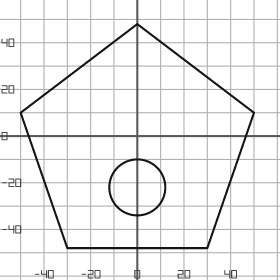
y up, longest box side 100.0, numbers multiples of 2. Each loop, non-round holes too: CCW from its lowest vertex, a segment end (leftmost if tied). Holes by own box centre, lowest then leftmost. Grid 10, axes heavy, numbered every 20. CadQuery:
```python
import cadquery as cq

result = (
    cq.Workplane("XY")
    .moveTo(-30.0, -48.0)
    .lineTo(30.0, -48.0)
    .lineTo(50.0, 10.0)
    .lineTo(0.0, 48.0)
    .lineTo(-50.0, 10.0)
    .close()
    .moveTo(0.0, -22.0)
    .circle(12.0)
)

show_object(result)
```